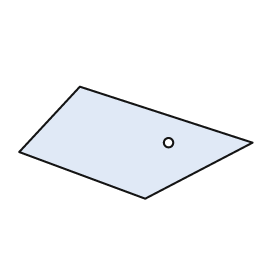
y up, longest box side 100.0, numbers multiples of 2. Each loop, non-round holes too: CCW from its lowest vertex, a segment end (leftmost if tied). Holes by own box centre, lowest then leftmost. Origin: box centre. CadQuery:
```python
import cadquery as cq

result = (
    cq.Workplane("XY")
    .moveTo(4.0, -24.0)
    .lineTo(50.0, 0.0)
    .lineTo(-24.0, 24.0)
    .lineTo(-50.0, -4.0)
    .close()
    .moveTo(14.0, 0.0)
    .circle(2.0)
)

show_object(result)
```